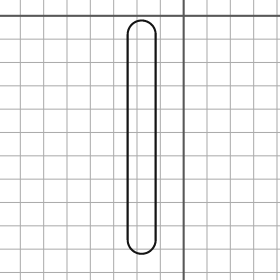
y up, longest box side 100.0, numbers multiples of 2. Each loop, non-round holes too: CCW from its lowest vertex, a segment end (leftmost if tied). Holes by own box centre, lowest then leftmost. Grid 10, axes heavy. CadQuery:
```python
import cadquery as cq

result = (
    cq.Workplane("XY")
    .moveTo(-24.0, -96.0)
    .threePointArc((-18.0, -102.0), (-12.0, -96.0))
    .lineTo(-12.0, -8.0)
    .threePointArc((-18.0, -2.0), (-24.0, -8.0))
    .close()
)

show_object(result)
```